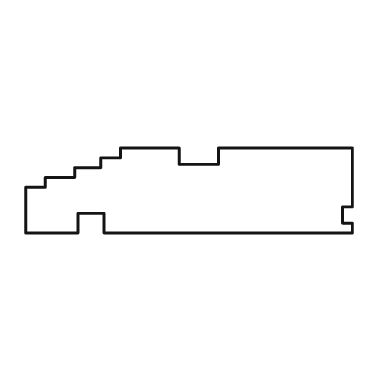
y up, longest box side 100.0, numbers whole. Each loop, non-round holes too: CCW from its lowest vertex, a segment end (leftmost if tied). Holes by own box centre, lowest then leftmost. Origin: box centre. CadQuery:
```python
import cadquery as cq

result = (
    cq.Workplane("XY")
    .moveTo(-50.0, -13.0)
    .lineTo(-34.0, -13.0)
    .lineTo(-34.0, -7.0)
    .lineTo(-26.0, -7.0)
    .lineTo(-26.0, -13.0)
    .lineTo(50.0, -13.0)
    .lineTo(50.0, -10.0)
    .lineTo(47.0, -10.0)
    .lineTo(47.0, -5.0)
    .lineTo(50.0, -5.0)
    .lineTo(50.0, 13.0)
    .lineTo(9.0, 13.0)
    .lineTo(9.0, 8.0)
    .lineTo(-3.0, 8.0)
    .lineTo(-3.0, 13.0)
    .lineTo(-21.0, 13.0)
    .lineTo(-21.0, 10.0)
    .lineTo(-27.0, 10.0)
    .lineTo(-27.0, 7.0)
    .lineTo(-35.0, 7.0)
    .lineTo(-35.0, 4.0)
    .lineTo(-44.0, 4.0)
    .lineTo(-44.0, 1.0)
    .lineTo(-50.0, 1.0)
    .close()
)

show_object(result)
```